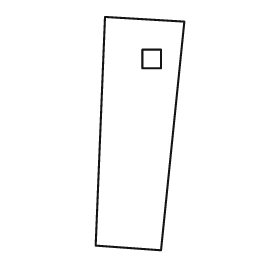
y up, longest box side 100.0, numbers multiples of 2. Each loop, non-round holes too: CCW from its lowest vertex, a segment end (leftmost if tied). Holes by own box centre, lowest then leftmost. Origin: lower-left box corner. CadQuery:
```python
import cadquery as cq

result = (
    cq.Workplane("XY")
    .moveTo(28.0, 0.0)
    .lineTo(38.0, 98.0)
    .lineTo(4.0, 100.0)
    .lineTo(0.0, 2.0)
    .close()
    .moveTo(20.0, 78.0)
    .lineTo(28.0, 78.0)
    .lineTo(28.0, 86.0)
    .lineTo(20.0, 86.0)
    .close()
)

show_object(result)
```